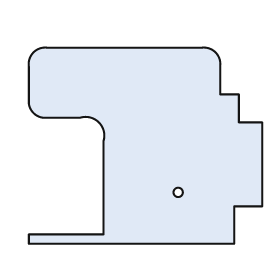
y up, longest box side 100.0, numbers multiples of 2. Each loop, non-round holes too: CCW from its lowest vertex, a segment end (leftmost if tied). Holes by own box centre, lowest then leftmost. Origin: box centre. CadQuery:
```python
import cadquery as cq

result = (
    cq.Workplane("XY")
    .moveTo(-50.0, -42.0)
    .lineTo(38.0, -42.0)
    .lineTo(38.0, -26.0)
    .lineTo(50.0, -26.0)
    .lineTo(50.0, 10.0)
    .lineTo(40.0, 10.0)
    .lineTo(40.0, 22.0)
    .lineTo(32.0, 22.0)
    .lineTo(32.0, 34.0)
    .threePointArc((30.0, 40.0), (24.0, 42.0))
    .lineTo(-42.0, 42.0)
    .threePointArc((-48.0, 40.0), (-50.0, 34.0))
    .lineTo(-50.0, 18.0)
    .threePointArc((-48.0, 14.0), (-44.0, 12.0))
    .lineTo(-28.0, 12.0)
    .threePointArc((-20.0, 10.0), (-18.0, 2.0))
    .lineTo(-18.0, -38.0)
    .lineTo(-50.0, -38.0)
    .close()
    .moveTo(14.0, -20.0)
    .circle(2.0)
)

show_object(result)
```